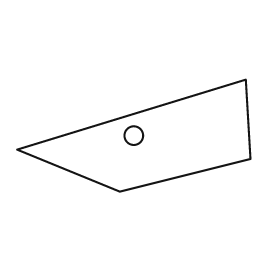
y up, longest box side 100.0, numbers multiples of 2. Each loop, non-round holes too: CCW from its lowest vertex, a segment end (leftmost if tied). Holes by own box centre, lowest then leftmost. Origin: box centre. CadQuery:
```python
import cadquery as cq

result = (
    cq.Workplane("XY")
    .moveTo(-6.0, -24.0)
    .lineTo(50.0, -10.0)
    .lineTo(48.0, 24.0)
    .lineTo(-50.0, -6.0)
    .close()
    .moveTo(0.0, 0.0)
    .circle(4.0)
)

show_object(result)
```